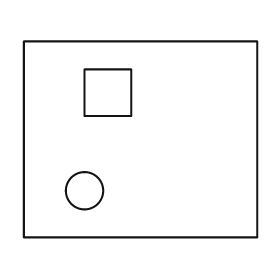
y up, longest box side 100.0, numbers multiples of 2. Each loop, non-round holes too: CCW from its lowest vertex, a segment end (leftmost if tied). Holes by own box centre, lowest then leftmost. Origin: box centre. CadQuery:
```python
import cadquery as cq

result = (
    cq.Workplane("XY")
    .moveTo(-50.0, -42.0)
    .lineTo(50.0, -42.0)
    .lineTo(50.0, 42.0)
    .lineTo(-50.0, 42.0)
    .close()
    .moveTo(-24.0, -22.0)
    .circle(8.0)
    .moveTo(-24.0, 10.0)
    .lineTo(-4.0, 10.0)
    .lineTo(-4.0, 30.0)
    .lineTo(-24.0, 30.0)
    .close()
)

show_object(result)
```